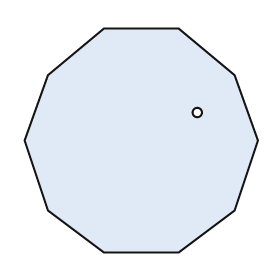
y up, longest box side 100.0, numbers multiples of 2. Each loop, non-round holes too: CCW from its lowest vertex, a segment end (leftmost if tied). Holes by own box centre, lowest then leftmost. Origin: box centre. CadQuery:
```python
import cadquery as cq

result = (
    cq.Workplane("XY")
    .moveTo(-16.0, -48.0)
    .lineTo(16.0, -48.0)
    .lineTo(40.0, -30.0)
    .lineTo(50.0, 0.0)
    .lineTo(40.0, 28.0)
    .lineTo(16.0, 48.0)
    .lineTo(-16.0, 48.0)
    .lineTo(-40.0, 28.0)
    .lineTo(-50.0, 0.0)
    .lineTo(-40.0, -30.0)
    .close()
    .moveTo(24.0, 12.0)
    .circle(2.0)
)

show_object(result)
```